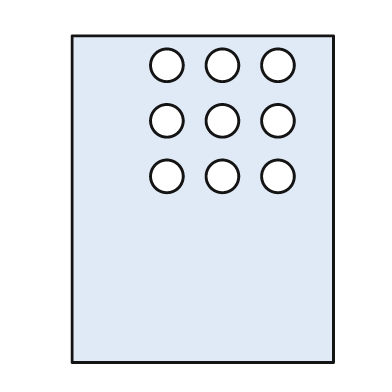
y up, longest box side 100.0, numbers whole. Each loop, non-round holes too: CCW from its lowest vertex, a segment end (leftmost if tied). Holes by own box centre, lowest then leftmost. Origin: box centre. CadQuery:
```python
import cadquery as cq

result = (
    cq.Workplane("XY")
    .moveTo(-40.0, -50.0)
    .lineTo(40.0, -50.0)
    .lineTo(40.0, 50.0)
    .lineTo(-40.0, 50.0)
    .close()
    .moveTo(-11.0, 7.0)
    .circle(5.0)
    .moveTo(6.0, 7.0)
    .circle(5.0)
    .moveTo(23.0, 7.0)
    .circle(5.0)
    .moveTo(-11.0, 24.0)
    .circle(5.0)
    .moveTo(6.0, 24.0)
    .circle(5.0)
    .moveTo(23.0, 24.0)
    .circle(5.0)
    .moveTo(-11.0, 41.0)
    .circle(5.0)
    .moveTo(6.0, 41.0)
    .circle(5.0)
    .moveTo(23.0, 41.0)
    .circle(5.0)
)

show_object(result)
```